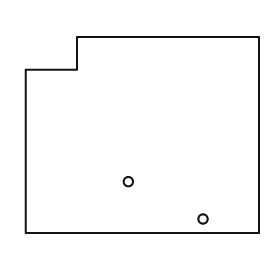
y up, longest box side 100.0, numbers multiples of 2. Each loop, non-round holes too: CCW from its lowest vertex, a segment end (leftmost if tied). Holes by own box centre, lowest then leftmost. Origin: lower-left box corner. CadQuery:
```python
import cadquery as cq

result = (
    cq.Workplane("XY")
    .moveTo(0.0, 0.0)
    .lineTo(100.0, 0.0)
    .lineTo(100.0, 84.0)
    .lineTo(22.0, 84.0)
    .lineTo(22.0, 70.0)
    .lineTo(0.0, 70.0)
    .close()
    .moveTo(76.0, 6.0)
    .circle(2.0)
    .moveTo(44.0, 22.0)
    .circle(2.0)
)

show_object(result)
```